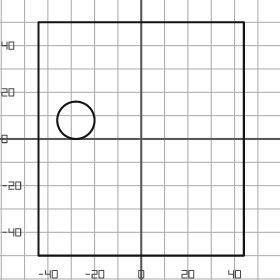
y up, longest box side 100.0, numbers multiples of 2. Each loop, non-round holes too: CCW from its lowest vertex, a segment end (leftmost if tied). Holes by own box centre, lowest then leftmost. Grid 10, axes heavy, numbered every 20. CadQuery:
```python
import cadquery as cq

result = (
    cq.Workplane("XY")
    .moveTo(-44.0, -50.0)
    .lineTo(44.0, -50.0)
    .lineTo(44.0, 50.0)
    .lineTo(-44.0, 50.0)
    .close()
    .moveTo(-28.0, 8.0)
    .circle(8.0)
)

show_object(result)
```